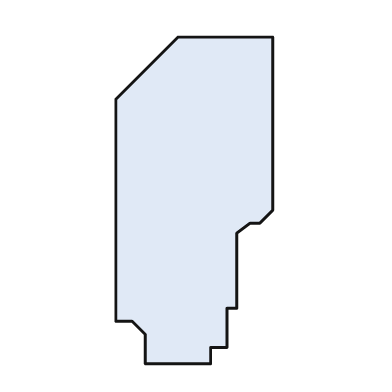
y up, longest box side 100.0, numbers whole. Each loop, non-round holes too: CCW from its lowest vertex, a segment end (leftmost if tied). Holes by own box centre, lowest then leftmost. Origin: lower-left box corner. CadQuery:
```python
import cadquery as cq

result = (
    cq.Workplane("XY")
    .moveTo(9.0, 0.0)
    .lineTo(29.0, 0.0)
    .lineTo(29.0, 5.0)
    .lineTo(34.0, 5.0)
    .lineTo(34.0, 17.0)
    .lineTo(37.0, 17.0)
    .lineTo(37.0, 40.0)
    .lineTo(41.0, 43.0)
    .lineTo(44.0, 43.0)
    .lineTo(48.0, 47.0)
    .lineTo(48.0, 100.0)
    .lineTo(19.0, 100.0)
    .lineTo(0.0, 81.0)
    .lineTo(0.0, 13.0)
    .lineTo(5.0, 13.0)
    .lineTo(9.0, 9.0)
    .close()
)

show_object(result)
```